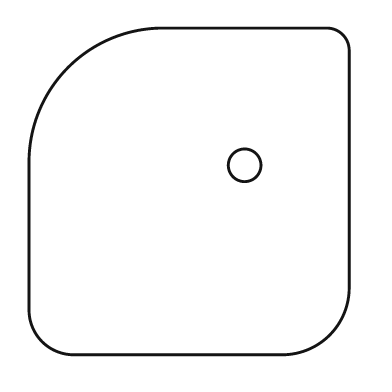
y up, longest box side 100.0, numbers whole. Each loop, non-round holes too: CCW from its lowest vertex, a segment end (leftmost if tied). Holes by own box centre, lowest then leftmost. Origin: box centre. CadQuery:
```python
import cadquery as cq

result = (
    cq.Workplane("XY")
    .moveTo(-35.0, -50.0)
    .lineTo(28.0, -50.0)
    .threePointArc((43.0, -44.0), (49.0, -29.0))
    .lineTo(49.0, 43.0)
    .threePointArc((47.0, 48.0), (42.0, 50.0))
    .lineTo(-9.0, 50.0)
    .threePointArc((-37.0, 38.0), (-49.0, 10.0))
    .lineTo(-49.0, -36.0)
    .threePointArc((-45.0, -46.0), (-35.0, -50.0))
    .close()
    .moveTo(17.0, 8.0)
    .circle(5.0)
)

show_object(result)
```